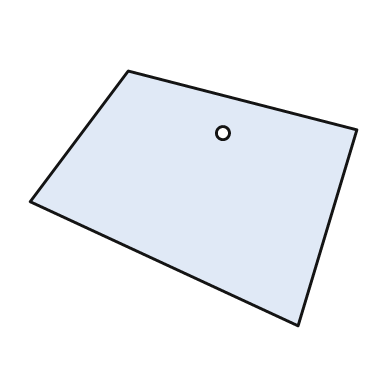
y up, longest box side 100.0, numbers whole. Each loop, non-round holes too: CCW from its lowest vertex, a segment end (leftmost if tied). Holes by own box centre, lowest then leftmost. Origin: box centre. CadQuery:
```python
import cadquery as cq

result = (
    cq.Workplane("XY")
    .moveTo(32.0, -39.0)
    .lineTo(50.0, 21.0)
    .lineTo(-20.0, 39.0)
    .lineTo(-50.0, -1.0)
    .close()
    .moveTo(9.0, 20.0)
    .circle(2.0)
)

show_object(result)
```